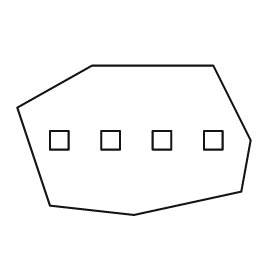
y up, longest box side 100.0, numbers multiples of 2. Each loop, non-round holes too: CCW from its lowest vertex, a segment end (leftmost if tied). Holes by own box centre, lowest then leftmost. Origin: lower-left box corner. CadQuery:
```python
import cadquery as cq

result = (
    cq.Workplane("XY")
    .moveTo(50.0, 0.0)
    .lineTo(96.0, 10.0)
    .lineTo(100.0, 32.0)
    .lineTo(84.0, 64.0)
    .lineTo(32.0, 64.0)
    .lineTo(0.0, 46.0)
    .lineTo(14.0, 4.0)
    .close()
    .moveTo(14.0, 28.0)
    .lineTo(22.0, 28.0)
    .lineTo(22.0, 36.0)
    .lineTo(14.0, 36.0)
    .close()
    .moveTo(36.0, 28.0)
    .lineTo(44.0, 28.0)
    .lineTo(44.0, 36.0)
    .lineTo(36.0, 36.0)
    .close()
    .moveTo(58.0, 28.0)
    .lineTo(66.0, 28.0)
    .lineTo(66.0, 36.0)
    .lineTo(58.0, 36.0)
    .close()
    .moveTo(80.0, 28.0)
    .lineTo(88.0, 28.0)
    .lineTo(88.0, 36.0)
    .lineTo(80.0, 36.0)
    .close()
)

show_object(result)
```